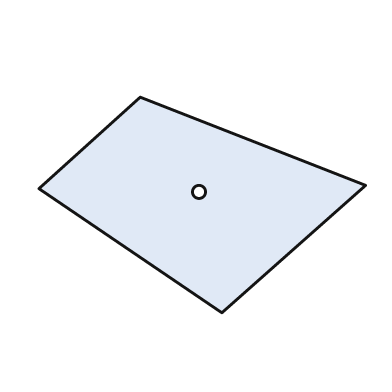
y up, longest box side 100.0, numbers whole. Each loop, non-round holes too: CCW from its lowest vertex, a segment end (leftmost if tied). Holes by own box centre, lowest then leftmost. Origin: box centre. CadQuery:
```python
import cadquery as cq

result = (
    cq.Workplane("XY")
    .moveTo(6.0, -33.0)
    .lineTo(50.0, 6.0)
    .lineTo(-19.0, 33.0)
    .lineTo(-50.0, 5.0)
    .close()
    .moveTo(-1.0, 4.0)
    .circle(2.0)
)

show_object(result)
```